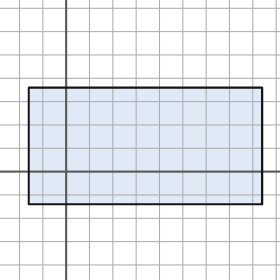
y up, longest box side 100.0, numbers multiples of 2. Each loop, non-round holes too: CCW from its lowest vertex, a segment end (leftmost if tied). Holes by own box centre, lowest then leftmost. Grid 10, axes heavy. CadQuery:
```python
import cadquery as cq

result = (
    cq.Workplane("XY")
    .moveTo(-16.0, -14.0)
    .lineTo(84.0, -14.0)
    .lineTo(84.0, 36.0)
    .lineTo(-16.0, 36.0)
    .close()
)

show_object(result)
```